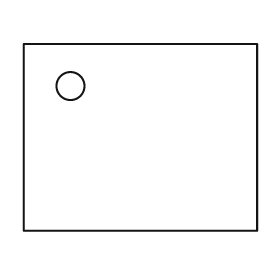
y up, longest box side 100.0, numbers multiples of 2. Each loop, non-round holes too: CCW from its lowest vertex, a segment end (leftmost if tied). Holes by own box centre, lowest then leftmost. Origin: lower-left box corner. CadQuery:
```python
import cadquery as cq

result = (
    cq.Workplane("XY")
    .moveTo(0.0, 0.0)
    .lineTo(100.0, 0.0)
    .lineTo(100.0, 80.0)
    .lineTo(0.0, 80.0)
    .close()
    .moveTo(20.0, 62.0)
    .circle(6.0)
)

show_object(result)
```